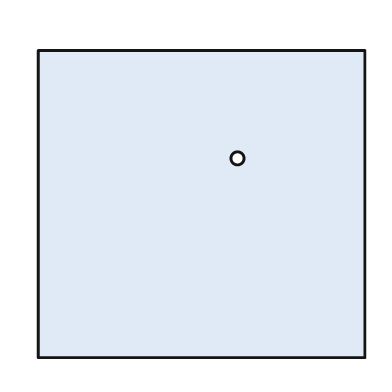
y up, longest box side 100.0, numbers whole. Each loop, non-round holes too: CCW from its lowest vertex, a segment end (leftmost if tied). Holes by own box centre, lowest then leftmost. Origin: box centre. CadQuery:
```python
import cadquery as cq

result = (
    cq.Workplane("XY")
    .moveTo(-50.0, -47.0)
    .lineTo(50.0, -47.0)
    .lineTo(50.0, 47.0)
    .lineTo(-50.0, 47.0)
    .close()
    .moveTo(11.0, 14.0)
    .circle(2.0)
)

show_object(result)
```